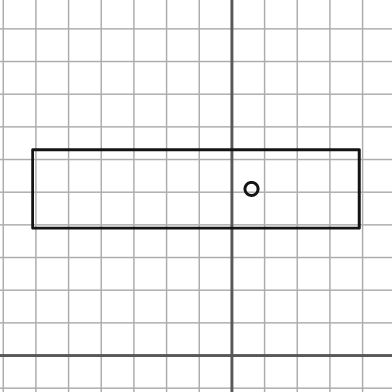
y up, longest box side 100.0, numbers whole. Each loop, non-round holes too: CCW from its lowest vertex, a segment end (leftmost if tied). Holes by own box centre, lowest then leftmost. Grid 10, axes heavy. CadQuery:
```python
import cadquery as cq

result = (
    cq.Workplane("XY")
    .moveTo(-61.0, 39.0)
    .lineTo(39.0, 39.0)
    .lineTo(39.0, 63.0)
    .lineTo(-61.0, 63.0)
    .close()
    .moveTo(6.0, 51.0)
    .circle(2.0)
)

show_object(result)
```